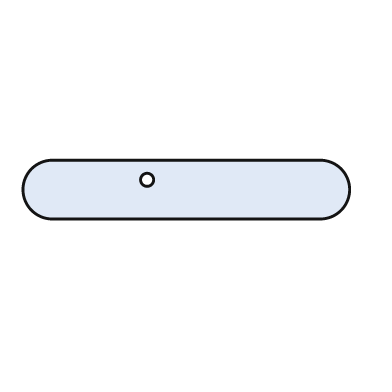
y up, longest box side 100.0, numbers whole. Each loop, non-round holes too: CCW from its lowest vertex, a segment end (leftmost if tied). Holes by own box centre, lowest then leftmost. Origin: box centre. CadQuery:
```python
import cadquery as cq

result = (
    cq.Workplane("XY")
    .moveTo(-41.0, -9.0)
    .lineTo(41.0, -9.0)
    .threePointArc((50.0, 0.0), (41.0, 9.0))
    .lineTo(-41.0, 9.0)
    .threePointArc((-50.0, 0.0), (-41.0, -9.0))
    .close()
    .moveTo(-12.0, 3.0)
    .circle(2.0)
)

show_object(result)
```